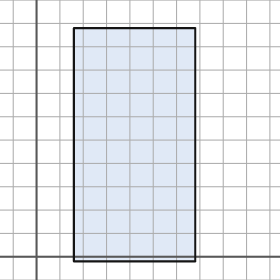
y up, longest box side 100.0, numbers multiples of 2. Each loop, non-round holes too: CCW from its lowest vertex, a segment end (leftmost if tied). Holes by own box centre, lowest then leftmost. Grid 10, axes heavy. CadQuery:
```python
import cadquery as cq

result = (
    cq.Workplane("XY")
    .moveTo(16.0, -2.0)
    .lineTo(68.0, -2.0)
    .lineTo(68.0, 98.0)
    .lineTo(16.0, 98.0)
    .close()
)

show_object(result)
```